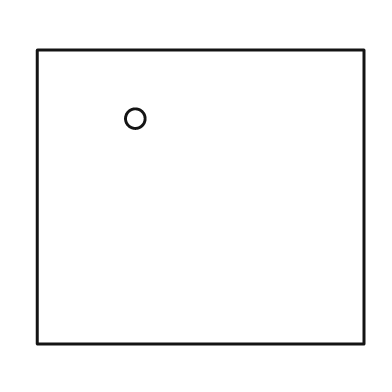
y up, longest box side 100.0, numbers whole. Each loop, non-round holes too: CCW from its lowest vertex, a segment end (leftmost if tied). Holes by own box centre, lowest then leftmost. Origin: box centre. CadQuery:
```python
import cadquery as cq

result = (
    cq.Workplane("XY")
    .moveTo(-50.0, -45.0)
    .lineTo(50.0, -45.0)
    .lineTo(50.0, 45.0)
    .lineTo(-50.0, 45.0)
    .close()
    .moveTo(-20.0, 24.0)
    .circle(3.0)
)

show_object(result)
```